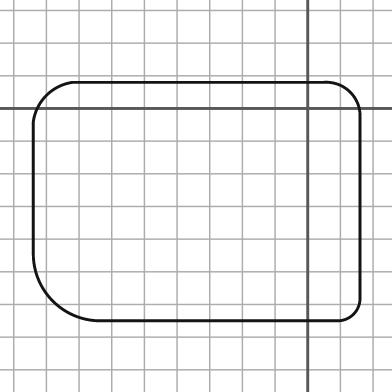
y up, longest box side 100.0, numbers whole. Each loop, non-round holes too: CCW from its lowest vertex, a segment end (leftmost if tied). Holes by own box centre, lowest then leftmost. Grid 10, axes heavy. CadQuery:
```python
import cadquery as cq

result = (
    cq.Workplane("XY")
    .moveTo(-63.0, -65.0)
    .lineTo(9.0, -65.0)
    .threePointArc((14.0, -63.0), (16.0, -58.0))
    .lineTo(16.0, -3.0)
    .threePointArc((13.0, 5.0), (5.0, 8.0))
    .lineTo(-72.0, 8.0)
    .threePointArc((-80.0, 4.0), (-84.0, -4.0))
    .lineTo(-84.0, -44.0)
    .threePointArc((-78.0, -59.0), (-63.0, -65.0))
    .close()
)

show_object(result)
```